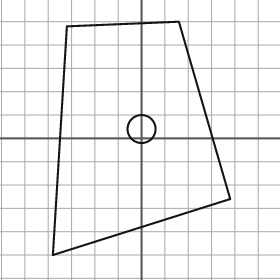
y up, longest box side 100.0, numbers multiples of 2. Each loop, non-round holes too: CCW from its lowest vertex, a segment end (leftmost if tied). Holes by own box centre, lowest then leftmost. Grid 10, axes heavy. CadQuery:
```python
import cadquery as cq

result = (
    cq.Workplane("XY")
    .moveTo(-38.0, -50.0)
    .lineTo(38.0, -26.0)
    .lineTo(16.0, 50.0)
    .lineTo(-32.0, 48.0)
    .close()
    .moveTo(0.0, 4.0)
    .circle(6.0)
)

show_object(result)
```